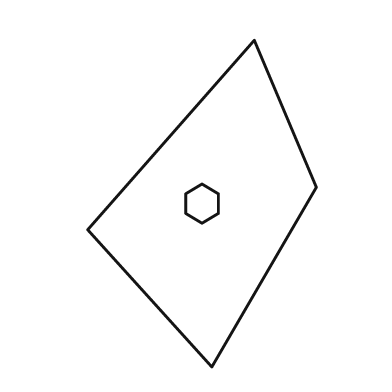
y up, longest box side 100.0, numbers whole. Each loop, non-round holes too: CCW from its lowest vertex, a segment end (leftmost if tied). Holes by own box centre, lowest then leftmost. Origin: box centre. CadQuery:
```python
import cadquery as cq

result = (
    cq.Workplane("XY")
    .moveTo(3.0, -50.0)
    .lineTo(35.0, 5.0)
    .lineTo(16.0, 50.0)
    .lineTo(-35.0, -8.0)
    .close()
    .moveTo(0.0, -6.0)
    .lineTo(5.0, -3.0)
    .lineTo(5.0, 3.0)
    .lineTo(0.0, 6.0)
    .lineTo(-5.0, 3.0)
    .lineTo(-5.0, -3.0)
    .close()
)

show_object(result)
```